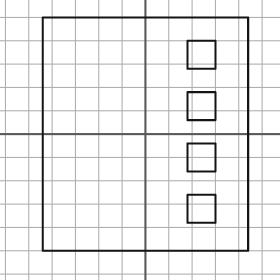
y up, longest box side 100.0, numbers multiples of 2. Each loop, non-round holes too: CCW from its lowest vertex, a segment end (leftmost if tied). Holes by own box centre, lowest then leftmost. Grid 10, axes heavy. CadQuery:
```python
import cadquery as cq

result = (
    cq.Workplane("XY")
    .moveTo(-44.0, -50.0)
    .lineTo(44.0, -50.0)
    .lineTo(44.0, 50.0)
    .lineTo(-44.0, 50.0)
    .close()
    .moveTo(18.0, -38.0)
    .lineTo(30.0, -38.0)
    .lineTo(30.0, -26.0)
    .lineTo(18.0, -26.0)
    .close()
    .moveTo(18.0, -16.0)
    .lineTo(30.0, -16.0)
    .lineTo(30.0, -4.0)
    .lineTo(18.0, -4.0)
    .close()
    .moveTo(18.0, 6.0)
    .lineTo(30.0, 6.0)
    .lineTo(30.0, 18.0)
    .lineTo(18.0, 18.0)
    .close()
    .moveTo(18.0, 28.0)
    .lineTo(30.0, 28.0)
    .lineTo(30.0, 40.0)
    .lineTo(18.0, 40.0)
    .close()
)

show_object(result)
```